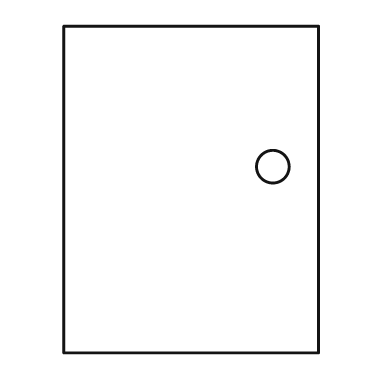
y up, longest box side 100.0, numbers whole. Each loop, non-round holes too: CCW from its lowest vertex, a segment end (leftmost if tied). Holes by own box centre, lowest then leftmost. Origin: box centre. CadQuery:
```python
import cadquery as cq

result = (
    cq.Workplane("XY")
    .moveTo(-39.0, -50.0)
    .lineTo(39.0, -50.0)
    .lineTo(39.0, 50.0)
    .lineTo(-39.0, 50.0)
    .close()
    .moveTo(25.0, 7.0)
    .circle(5.0)
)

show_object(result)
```